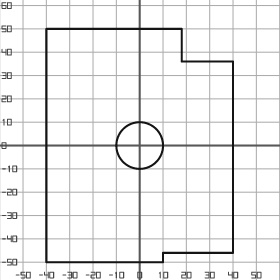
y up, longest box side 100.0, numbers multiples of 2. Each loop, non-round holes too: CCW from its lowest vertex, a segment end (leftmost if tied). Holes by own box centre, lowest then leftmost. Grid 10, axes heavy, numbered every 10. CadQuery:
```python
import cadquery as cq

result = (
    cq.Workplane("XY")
    .moveTo(-40.0, -50.0)
    .lineTo(10.0, -50.0)
    .lineTo(10.0, -46.0)
    .lineTo(40.0, -46.0)
    .lineTo(40.0, 36.0)
    .lineTo(18.0, 36.0)
    .lineTo(18.0, 50.0)
    .lineTo(-40.0, 50.0)
    .close()
    .moveTo(0.0, 0.0)
    .circle(10.0)
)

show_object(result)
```